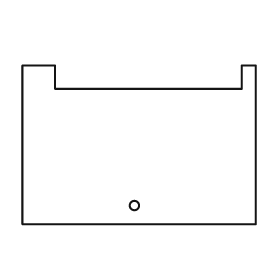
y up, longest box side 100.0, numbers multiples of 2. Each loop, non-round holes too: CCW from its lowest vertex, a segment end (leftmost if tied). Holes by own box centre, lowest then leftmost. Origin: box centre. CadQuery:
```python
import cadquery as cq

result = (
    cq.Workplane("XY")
    .moveTo(-50.0, -34.0)
    .lineTo(50.0, -34.0)
    .lineTo(50.0, 34.0)
    .lineTo(44.0, 34.0)
    .lineTo(44.0, 24.0)
    .lineTo(-36.0, 24.0)
    .lineTo(-36.0, 34.0)
    .lineTo(-50.0, 34.0)
    .close()
    .moveTo(-2.0, -26.0)
    .circle(2.0)
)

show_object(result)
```